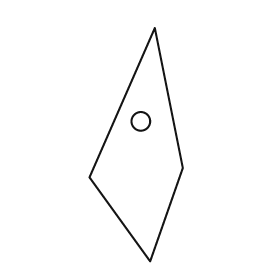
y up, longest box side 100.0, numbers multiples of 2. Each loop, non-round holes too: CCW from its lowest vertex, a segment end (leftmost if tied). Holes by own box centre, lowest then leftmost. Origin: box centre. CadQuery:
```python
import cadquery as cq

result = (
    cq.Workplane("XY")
    .moveTo(6.0, -50.0)
    .lineTo(20.0, -10.0)
    .lineTo(8.0, 50.0)
    .lineTo(-20.0, -14.0)
    .close()
    .moveTo(2.0, 10.0)
    .circle(4.0)
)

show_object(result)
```